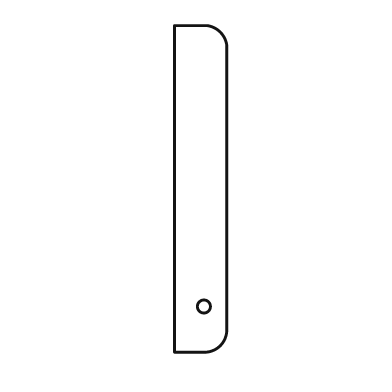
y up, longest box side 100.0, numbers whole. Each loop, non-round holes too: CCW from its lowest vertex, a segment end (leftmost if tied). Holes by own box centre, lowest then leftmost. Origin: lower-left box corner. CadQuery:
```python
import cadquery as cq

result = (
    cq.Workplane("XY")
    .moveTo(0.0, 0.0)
    .lineTo(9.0, 0.0)
    .threePointArc((14.0, 2.0), (16.0, 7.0))
    .lineTo(16.0, 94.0)
    .threePointArc((14.0, 98.0), (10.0, 100.0))
    .lineTo(0.0, 100.0)
    .close()
    .moveTo(9.0, 14.0)
    .circle(2.0)
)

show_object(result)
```